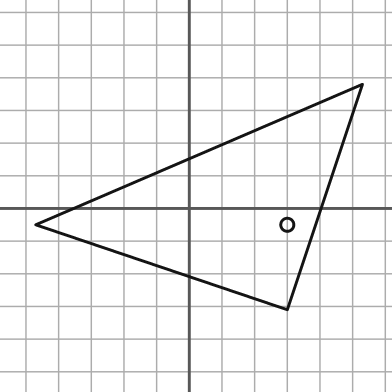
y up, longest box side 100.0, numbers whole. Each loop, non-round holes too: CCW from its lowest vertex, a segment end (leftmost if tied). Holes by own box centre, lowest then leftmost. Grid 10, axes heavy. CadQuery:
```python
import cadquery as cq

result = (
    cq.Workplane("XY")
    .moveTo(30.0, -31.0)
    .lineTo(53.0, 38.0)
    .lineTo(-47.0, -5.0)
    .close()
    .moveTo(30.0, -5.0)
    .circle(2.0)
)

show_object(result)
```